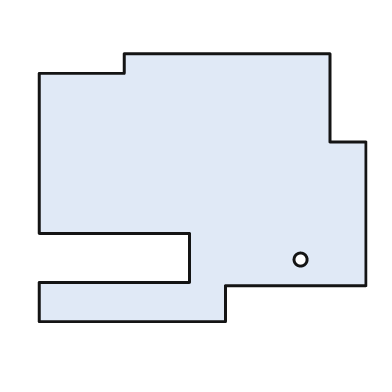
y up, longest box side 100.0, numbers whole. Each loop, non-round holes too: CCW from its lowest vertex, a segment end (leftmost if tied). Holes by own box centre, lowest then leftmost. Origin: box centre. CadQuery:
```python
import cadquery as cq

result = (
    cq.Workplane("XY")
    .moveTo(-50.0, -41.0)
    .lineTo(7.0, -41.0)
    .lineTo(7.0, -30.0)
    .lineTo(50.0, -30.0)
    .lineTo(50.0, 14.0)
    .lineTo(39.0, 14.0)
    .lineTo(39.0, 41.0)
    .lineTo(-24.0, 41.0)
    .lineTo(-24.0, 35.0)
    .lineTo(-50.0, 35.0)
    .lineTo(-50.0, -14.0)
    .lineTo(-4.0, -14.0)
    .lineTo(-4.0, -29.0)
    .lineTo(-50.0, -29.0)
    .close()
    .moveTo(30.0, -22.0)
    .circle(2.0)
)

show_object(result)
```